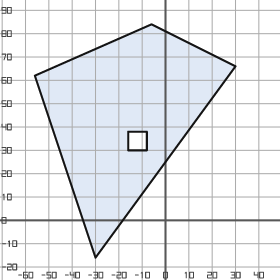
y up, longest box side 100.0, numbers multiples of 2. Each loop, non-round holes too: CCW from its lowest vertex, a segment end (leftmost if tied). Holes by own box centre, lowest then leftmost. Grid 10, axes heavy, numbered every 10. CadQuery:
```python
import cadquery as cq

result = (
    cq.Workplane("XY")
    .moveTo(-30.0, -16.0)
    .lineTo(30.0, 66.0)
    .lineTo(-6.0, 84.0)
    .lineTo(-56.0, 62.0)
    .close()
    .moveTo(-16.0, 30.0)
    .lineTo(-8.0, 30.0)
    .lineTo(-8.0, 38.0)
    .lineTo(-16.0, 38.0)
    .close()
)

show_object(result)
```